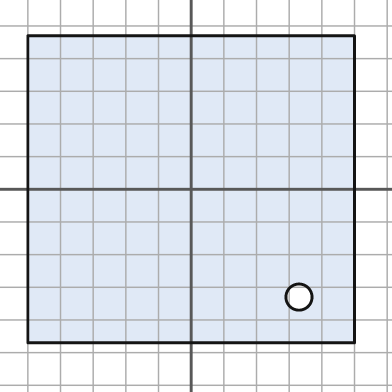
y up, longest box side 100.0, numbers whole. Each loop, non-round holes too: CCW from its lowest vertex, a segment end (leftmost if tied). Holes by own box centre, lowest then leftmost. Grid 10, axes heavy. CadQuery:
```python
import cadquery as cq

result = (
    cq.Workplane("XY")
    .moveTo(-50.0, -47.0)
    .lineTo(50.0, -47.0)
    .lineTo(50.0, 47.0)
    .lineTo(-50.0, 47.0)
    .close()
    .moveTo(33.0, -33.0)
    .circle(4.0)
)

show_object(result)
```